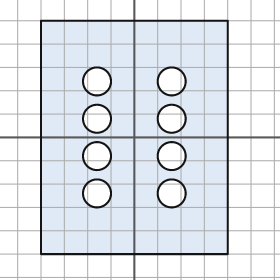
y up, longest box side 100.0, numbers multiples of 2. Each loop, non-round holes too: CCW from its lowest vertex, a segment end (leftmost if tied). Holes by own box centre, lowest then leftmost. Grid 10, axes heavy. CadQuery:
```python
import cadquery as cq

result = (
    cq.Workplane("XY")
    .moveTo(-40.0, -50.0)
    .lineTo(40.0, -50.0)
    .lineTo(40.0, 50.0)
    .lineTo(-40.0, 50.0)
    .close()
    .moveTo(-16.0, -24.0)
    .circle(6.0)
    .moveTo(16.0, -24.0)
    .circle(6.0)
    .moveTo(-16.0, -8.0)
    .circle(6.0)
    .moveTo(16.0, -8.0)
    .circle(6.0)
    .moveTo(-16.0, 8.0)
    .circle(6.0)
    .moveTo(16.0, 8.0)
    .circle(6.0)
    .moveTo(-16.0, 24.0)
    .circle(6.0)
    .moveTo(16.0, 24.0)
    .circle(6.0)
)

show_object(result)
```